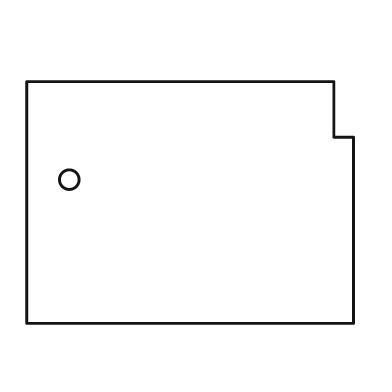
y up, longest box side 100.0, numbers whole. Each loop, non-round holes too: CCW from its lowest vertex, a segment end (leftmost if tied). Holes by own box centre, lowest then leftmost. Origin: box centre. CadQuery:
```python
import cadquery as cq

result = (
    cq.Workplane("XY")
    .moveTo(-50.0, -37.0)
    .lineTo(50.0, -37.0)
    .lineTo(50.0, 20.0)
    .lineTo(44.0, 20.0)
    .lineTo(44.0, 37.0)
    .lineTo(-50.0, 37.0)
    .close()
    .moveTo(-37.0, 7.0)
    .circle(3.0)
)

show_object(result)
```